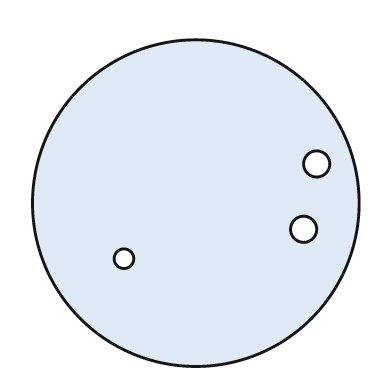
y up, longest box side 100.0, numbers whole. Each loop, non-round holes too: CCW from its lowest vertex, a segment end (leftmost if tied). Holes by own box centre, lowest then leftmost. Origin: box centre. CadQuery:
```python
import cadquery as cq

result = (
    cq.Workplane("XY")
    .moveTo(0.0, 0.0)
    .circle(50.0)
    .moveTo(-22.0, -17.0)
    .circle(3.0)
    .moveTo(33.0, -8.0)
    .circle(4.0)
    .moveTo(37.0, 12.0)
    .circle(4.0)
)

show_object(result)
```